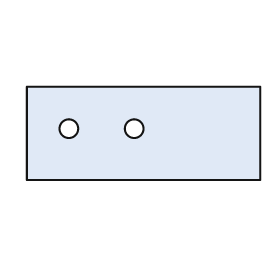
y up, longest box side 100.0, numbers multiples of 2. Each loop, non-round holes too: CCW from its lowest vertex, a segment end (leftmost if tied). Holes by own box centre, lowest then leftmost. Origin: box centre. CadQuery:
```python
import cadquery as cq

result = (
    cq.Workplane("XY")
    .moveTo(-50.0, -20.0)
    .lineTo(50.0, -20.0)
    .lineTo(50.0, 20.0)
    .lineTo(-50.0, 20.0)
    .close()
    .moveTo(-32.0, 2.0)
    .circle(4.0)
    .moveTo(-4.0, 2.0)
    .circle(4.0)
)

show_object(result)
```